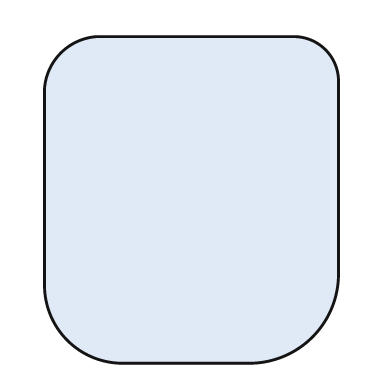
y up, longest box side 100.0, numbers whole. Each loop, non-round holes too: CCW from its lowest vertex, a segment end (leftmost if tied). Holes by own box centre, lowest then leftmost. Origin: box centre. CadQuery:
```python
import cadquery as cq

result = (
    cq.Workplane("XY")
    .moveTo(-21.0, -50.0)
    .lineTo(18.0, -50.0)
    .threePointArc((37.0, -42.0), (45.0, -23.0))
    .lineTo(45.0, 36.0)
    .threePointArc((41.0, 46.0), (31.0, 50.0))
    .lineTo(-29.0, 50.0)
    .threePointArc((-40.0, 45.0), (-45.0, 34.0))
    .lineTo(-45.0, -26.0)
    .threePointArc((-38.0, -43.0), (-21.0, -50.0))
    .close()
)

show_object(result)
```